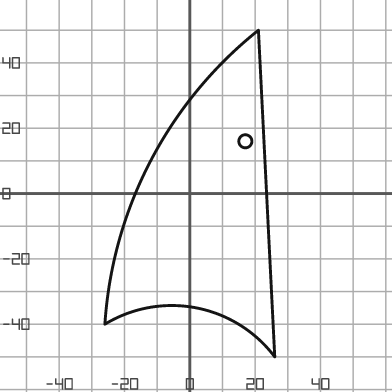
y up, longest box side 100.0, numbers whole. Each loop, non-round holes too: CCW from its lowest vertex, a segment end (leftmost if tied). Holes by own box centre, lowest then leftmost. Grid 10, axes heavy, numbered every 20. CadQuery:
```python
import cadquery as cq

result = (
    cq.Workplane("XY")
    .moveTo(26.0, -50.0)
    .lineTo(21.0, 50.0)
    .threePointArc((-12.0, 10.0), (-26.0, -40.0))
    .threePointArc((2.0, -35.0), (26.0, -50.0))
    .close()
    .moveTo(17.0, 16.0)
    .circle(2.0)
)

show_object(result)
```